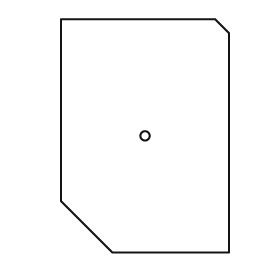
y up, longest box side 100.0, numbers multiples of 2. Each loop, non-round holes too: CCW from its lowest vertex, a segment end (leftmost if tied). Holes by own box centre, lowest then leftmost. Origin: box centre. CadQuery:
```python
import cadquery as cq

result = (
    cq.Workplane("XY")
    .moveTo(-14.0, -50.0)
    .lineTo(36.0, -50.0)
    .lineTo(36.0, 44.0)
    .lineTo(30.0, 50.0)
    .lineTo(-36.0, 50.0)
    .lineTo(-36.0, -28.0)
    .close()
    .moveTo(0.0, 0.0)
    .circle(2.0)
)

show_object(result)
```